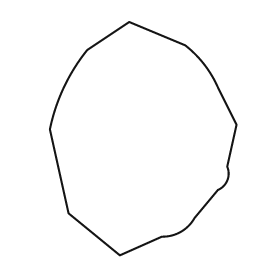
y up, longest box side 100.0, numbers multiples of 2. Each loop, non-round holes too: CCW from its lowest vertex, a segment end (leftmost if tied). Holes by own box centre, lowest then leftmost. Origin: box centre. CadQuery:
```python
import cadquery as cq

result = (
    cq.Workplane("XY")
    .moveTo(-10.0, -50.0)
    .lineTo(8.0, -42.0)
    .threePointArc((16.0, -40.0), (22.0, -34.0))
    .lineTo(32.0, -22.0)
    .threePointArc((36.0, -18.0), (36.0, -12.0))
    .lineTo(40.0, 6.0)
    .lineTo(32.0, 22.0)
    .threePointArc((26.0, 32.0), (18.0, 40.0))
    .lineTo(-6.0, 50.0)
    .lineTo(-24.0, 38.0)
    .threePointArc((-34.0, 22.0), (-40.0, 4.0))
    .lineTo(-32.0, -32.0)
    .close()
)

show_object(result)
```